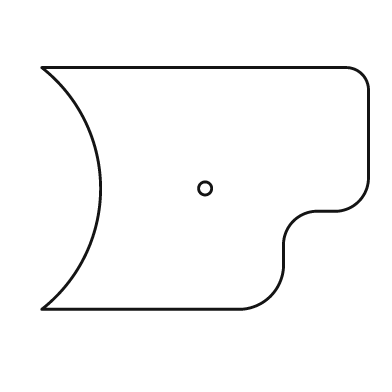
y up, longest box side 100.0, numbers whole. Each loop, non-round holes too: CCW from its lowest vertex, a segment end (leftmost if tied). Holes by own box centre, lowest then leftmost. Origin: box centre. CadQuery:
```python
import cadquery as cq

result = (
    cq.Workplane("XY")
    .moveTo(-50.0, -37.0)
    .lineTo(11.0, -37.0)
    .threePointArc((20.0, -33.0), (24.0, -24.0))
    .lineTo(24.0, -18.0)
    .threePointArc((27.0, -10.0), (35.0, -7.0))
    .lineTo(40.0, -7.0)
    .threePointArc((47.0, -4.0), (50.0, 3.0))
    .lineTo(50.0, 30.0)
    .threePointArc((48.0, 35.0), (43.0, 37.0))
    .lineTo(-50.0, 37.0)
    .threePointArc((-32.0, 0.0), (-50.0, -37.0))
    .close()
    .moveTo(0.0, 0.0)
    .circle(2.0)
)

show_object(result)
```